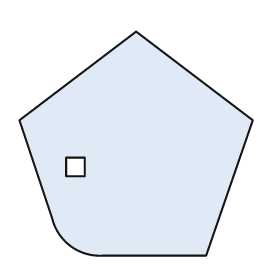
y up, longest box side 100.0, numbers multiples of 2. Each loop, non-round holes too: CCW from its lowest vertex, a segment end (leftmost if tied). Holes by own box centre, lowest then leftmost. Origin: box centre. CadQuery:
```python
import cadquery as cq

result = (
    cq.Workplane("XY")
    .moveTo(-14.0, -48.0)
    .lineTo(30.0, -48.0)
    .lineTo(50.0, 10.0)
    .lineTo(0.0, 48.0)
    .lineTo(-50.0, 10.0)
    .lineTo(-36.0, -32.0)
    .threePointArc((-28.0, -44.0), (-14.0, -48.0))
    .close()
    .moveTo(-30.0, -14.0)
    .lineTo(-22.0, -14.0)
    .lineTo(-22.0, -6.0)
    .lineTo(-30.0, -6.0)
    .close()
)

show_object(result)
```